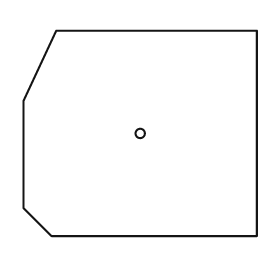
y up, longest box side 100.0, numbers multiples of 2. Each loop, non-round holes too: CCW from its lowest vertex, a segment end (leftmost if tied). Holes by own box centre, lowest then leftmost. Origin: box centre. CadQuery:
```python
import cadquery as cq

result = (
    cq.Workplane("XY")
    .moveTo(-38.0, -44.0)
    .lineTo(50.0, -44.0)
    .lineTo(50.0, 44.0)
    .lineTo(-36.0, 44.0)
    .lineTo(-50.0, 14.0)
    .lineTo(-50.0, -32.0)
    .close()
    .moveTo(0.0, 0.0)
    .circle(2.0)
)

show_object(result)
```